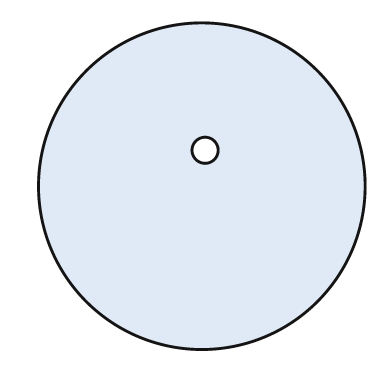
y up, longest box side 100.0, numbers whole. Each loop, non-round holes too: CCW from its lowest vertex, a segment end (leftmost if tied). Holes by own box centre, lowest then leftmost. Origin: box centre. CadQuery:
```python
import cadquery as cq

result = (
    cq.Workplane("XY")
    .moveTo(0.0, 0.0)
    .circle(50.0)
    .moveTo(1.0, 11.0)
    .circle(4.0)
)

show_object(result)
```